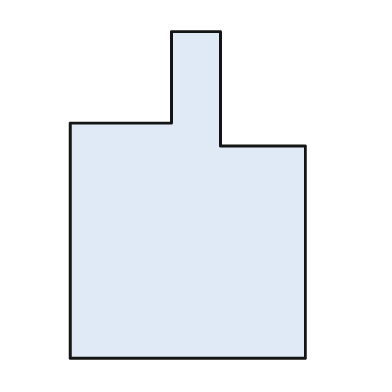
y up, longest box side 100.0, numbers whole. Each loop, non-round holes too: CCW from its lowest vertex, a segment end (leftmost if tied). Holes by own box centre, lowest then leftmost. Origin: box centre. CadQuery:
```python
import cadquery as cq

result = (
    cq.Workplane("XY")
    .moveTo(-36.0, -50.0)
    .lineTo(36.0, -50.0)
    .lineTo(36.0, 15.0)
    .lineTo(10.0, 15.0)
    .lineTo(10.0, 50.0)
    .lineTo(-5.0, 50.0)
    .lineTo(-5.0, 22.0)
    .lineTo(-36.0, 22.0)
    .close()
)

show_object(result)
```